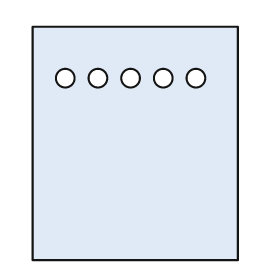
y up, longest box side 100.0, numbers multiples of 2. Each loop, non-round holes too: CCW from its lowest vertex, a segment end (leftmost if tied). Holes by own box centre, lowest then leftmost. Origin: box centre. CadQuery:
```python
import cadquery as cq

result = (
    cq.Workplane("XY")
    .moveTo(-44.0, -50.0)
    .lineTo(44.0, -50.0)
    .lineTo(44.0, 50.0)
    .lineTo(-44.0, 50.0)
    .close()
    .moveTo(-30.0, 28.0)
    .circle(4.0)
    .moveTo(-16.0, 28.0)
    .circle(4.0)
    .moveTo(-2.0, 28.0)
    .circle(4.0)
    .moveTo(12.0, 28.0)
    .circle(4.0)
    .moveTo(26.0, 28.0)
    .circle(4.0)
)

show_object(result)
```